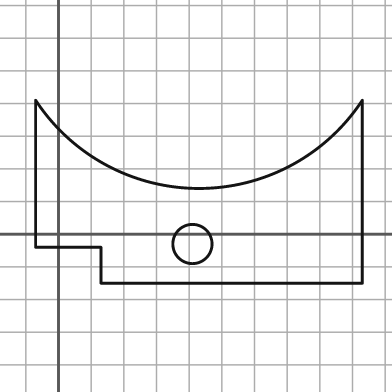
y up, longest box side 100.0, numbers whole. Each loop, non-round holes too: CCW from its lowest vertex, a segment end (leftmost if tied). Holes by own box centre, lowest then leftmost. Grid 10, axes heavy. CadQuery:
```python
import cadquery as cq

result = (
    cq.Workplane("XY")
    .moveTo(13.0, -15.0)
    .lineTo(93.0, -15.0)
    .lineTo(93.0, 41.0)
    .threePointArc((43.0, 14.0), (-7.0, 41.0))
    .lineTo(-7.0, -4.0)
    .lineTo(13.0, -4.0)
    .close()
    .moveTo(41.0, -3.0)
    .circle(6.0)
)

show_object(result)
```